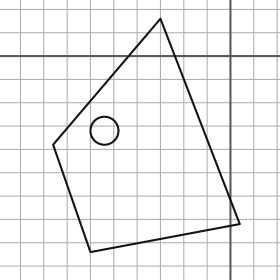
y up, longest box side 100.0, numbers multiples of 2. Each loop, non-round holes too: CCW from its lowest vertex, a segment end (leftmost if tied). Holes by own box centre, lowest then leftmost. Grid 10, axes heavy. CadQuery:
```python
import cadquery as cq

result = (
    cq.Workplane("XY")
    .moveTo(-60.0, -84.0)
    .lineTo(4.0, -72.0)
    .lineTo(-30.0, 16.0)
    .lineTo(-76.0, -38.0)
    .close()
    .moveTo(-54.0, -32.0)
    .circle(6.0)
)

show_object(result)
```